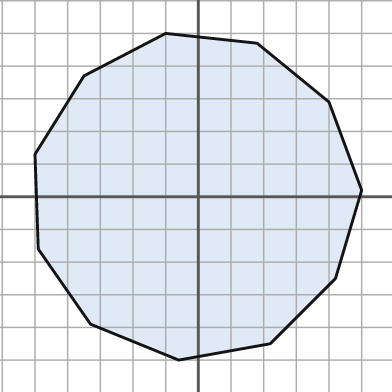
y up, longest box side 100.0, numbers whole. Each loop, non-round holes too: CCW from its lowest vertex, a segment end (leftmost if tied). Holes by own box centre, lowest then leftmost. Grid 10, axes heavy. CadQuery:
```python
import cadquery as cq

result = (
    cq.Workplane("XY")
    .moveTo(-6.0, -50.0)
    .lineTo(22.0, -45.0)
    .lineTo(42.0, -25.0)
    .lineTo(50.0, 2.0)
    .lineTo(40.0, 29.0)
    .lineTo(18.0, 47.0)
    .lineTo(-10.0, 50.0)
    .lineTo(-35.0, 37.0)
    .lineTo(-50.0, 13.0)
    .lineTo(-49.0, -16.0)
    .lineTo(-33.0, -39.0)
    .close()
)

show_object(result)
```